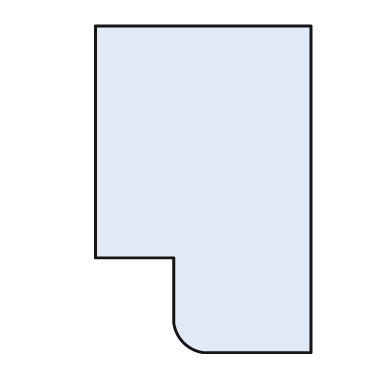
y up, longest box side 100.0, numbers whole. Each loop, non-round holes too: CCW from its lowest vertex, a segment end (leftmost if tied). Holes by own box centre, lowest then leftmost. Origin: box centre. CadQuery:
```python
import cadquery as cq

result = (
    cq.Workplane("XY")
    .moveTo(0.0, -50.0)
    .lineTo(33.0, -50.0)
    .lineTo(33.0, 50.0)
    .lineTo(-33.0, 50.0)
    .lineTo(-33.0, -21.0)
    .lineTo(-9.0, -21.0)
    .lineTo(-9.0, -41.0)
    .threePointArc((-6.0, -47.0), (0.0, -50.0))
    .close()
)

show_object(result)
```